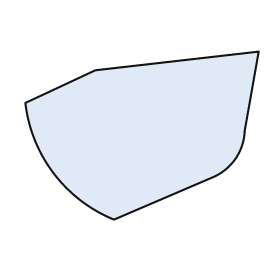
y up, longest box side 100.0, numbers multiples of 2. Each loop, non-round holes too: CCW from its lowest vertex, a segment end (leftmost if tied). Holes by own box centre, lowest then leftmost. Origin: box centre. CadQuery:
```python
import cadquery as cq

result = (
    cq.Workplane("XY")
    .moveTo(-12.0, -36.0)
    .lineTo(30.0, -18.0)
    .threePointArc((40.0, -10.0), (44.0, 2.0))
    .lineTo(50.0, 36.0)
    .lineTo(-20.0, 28.0)
    .lineTo(-50.0, 14.0)
    .threePointArc((-38.0, -16.0), (-12.0, -36.0))
    .close()
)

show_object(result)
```